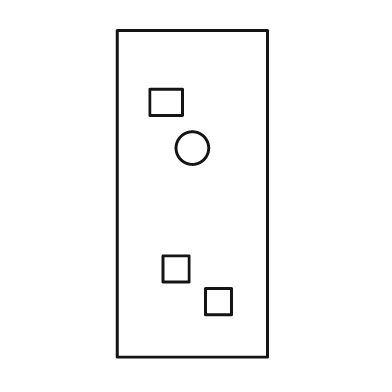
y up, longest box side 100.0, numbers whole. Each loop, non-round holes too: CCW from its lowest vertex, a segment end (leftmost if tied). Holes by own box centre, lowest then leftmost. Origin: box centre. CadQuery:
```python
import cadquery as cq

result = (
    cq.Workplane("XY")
    .moveTo(-23.0, -50.0)
    .lineTo(23.0, -50.0)
    .lineTo(23.0, 50.0)
    .lineTo(-23.0, 50.0)
    .close()
    .moveTo(4.0, -37.0)
    .lineTo(12.0, -37.0)
    .lineTo(12.0, -29.0)
    .lineTo(4.0, -29.0)
    .close()
    .moveTo(-9.0, -27.0)
    .lineTo(-1.0, -27.0)
    .lineTo(-1.0, -19.0)
    .lineTo(-9.0, -19.0)
    .close()
    .moveTo(0.0, 14.0)
    .circle(5.0)
    .moveTo(-13.0, 24.0)
    .lineTo(-3.0, 24.0)
    .lineTo(-3.0, 32.0)
    .lineTo(-13.0, 32.0)
    .close()
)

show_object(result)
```